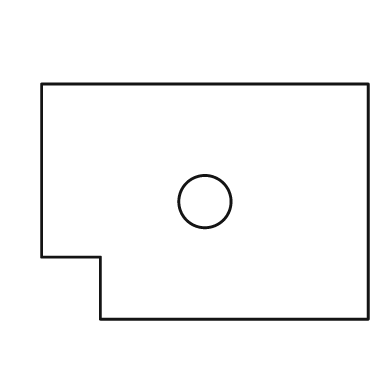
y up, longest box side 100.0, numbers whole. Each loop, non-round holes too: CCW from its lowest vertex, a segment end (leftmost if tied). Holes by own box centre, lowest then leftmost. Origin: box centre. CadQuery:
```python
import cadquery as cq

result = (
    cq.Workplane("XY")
    .moveTo(-32.0, -36.0)
    .lineTo(50.0, -36.0)
    .lineTo(50.0, 36.0)
    .lineTo(-50.0, 36.0)
    .lineTo(-50.0, -17.0)
    .lineTo(-32.0, -17.0)
    .close()
    .moveTo(0.0, 0.0)
    .circle(8.0)
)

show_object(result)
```